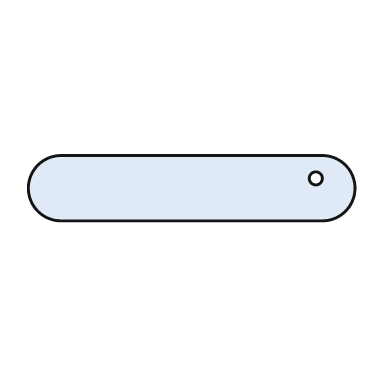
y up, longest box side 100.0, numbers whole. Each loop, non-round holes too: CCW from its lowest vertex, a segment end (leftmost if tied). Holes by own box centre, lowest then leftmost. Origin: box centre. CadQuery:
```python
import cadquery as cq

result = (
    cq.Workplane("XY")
    .moveTo(-40.0, -10.0)
    .lineTo(40.0, -10.0)
    .threePointArc((50.0, 0.0), (40.0, 10.0))
    .lineTo(-40.0, 10.0)
    .threePointArc((-50.0, 0.0), (-40.0, -10.0))
    .close()
    .moveTo(38.0, 3.0)
    .circle(2.0)
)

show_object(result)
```